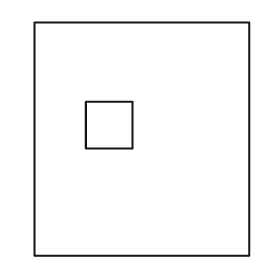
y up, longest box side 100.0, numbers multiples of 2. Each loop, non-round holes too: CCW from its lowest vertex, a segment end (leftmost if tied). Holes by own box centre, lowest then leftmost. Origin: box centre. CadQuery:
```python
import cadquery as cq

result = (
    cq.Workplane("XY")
    .moveTo(-46.0, -50.0)
    .lineTo(46.0, -50.0)
    .lineTo(46.0, 50.0)
    .lineTo(-46.0, 50.0)
    .close()
    .moveTo(-24.0, -4.0)
    .lineTo(-4.0, -4.0)
    .lineTo(-4.0, 16.0)
    .lineTo(-24.0, 16.0)
    .close()
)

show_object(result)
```